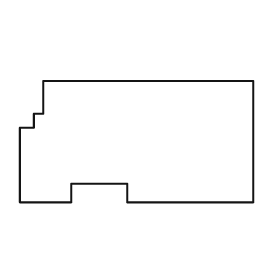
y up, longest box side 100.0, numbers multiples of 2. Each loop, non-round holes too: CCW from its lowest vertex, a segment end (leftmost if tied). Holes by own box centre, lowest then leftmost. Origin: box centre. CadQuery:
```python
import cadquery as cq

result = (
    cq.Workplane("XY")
    .moveTo(-50.0, -26.0)
    .lineTo(-28.0, -26.0)
    .lineTo(-28.0, -18.0)
    .lineTo(-4.0, -18.0)
    .lineTo(-4.0, -26.0)
    .lineTo(50.0, -26.0)
    .lineTo(50.0, 26.0)
    .lineTo(-40.0, 26.0)
    .lineTo(-40.0, 12.0)
    .lineTo(-44.0, 12.0)
    .lineTo(-44.0, 6.0)
    .lineTo(-50.0, 6.0)
    .close()
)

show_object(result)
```